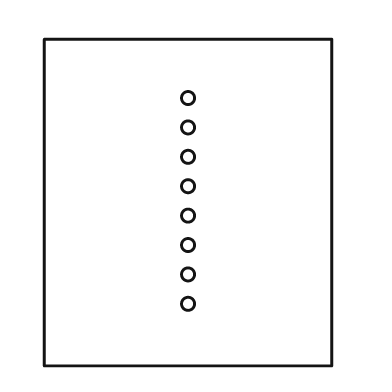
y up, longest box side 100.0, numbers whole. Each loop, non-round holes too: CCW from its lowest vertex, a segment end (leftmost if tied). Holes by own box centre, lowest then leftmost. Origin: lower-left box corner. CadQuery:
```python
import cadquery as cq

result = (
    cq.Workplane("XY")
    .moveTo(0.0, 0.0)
    .lineTo(88.0, 0.0)
    .lineTo(88.0, 100.0)
    .lineTo(0.0, 100.0)
    .close()
    .moveTo(44.0, 19.0)
    .circle(2.0)
    .moveTo(44.0, 28.0)
    .circle(2.0)
    .moveTo(44.0, 37.0)
    .circle(2.0)
    .moveTo(44.0, 46.0)
    .circle(2.0)
    .moveTo(44.0, 55.0)
    .circle(2.0)
    .moveTo(44.0, 64.0)
    .circle(2.0)
    .moveTo(44.0, 73.0)
    .circle(2.0)
    .moveTo(44.0, 82.0)
    .circle(2.0)
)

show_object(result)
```